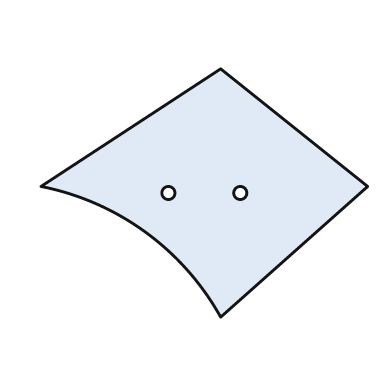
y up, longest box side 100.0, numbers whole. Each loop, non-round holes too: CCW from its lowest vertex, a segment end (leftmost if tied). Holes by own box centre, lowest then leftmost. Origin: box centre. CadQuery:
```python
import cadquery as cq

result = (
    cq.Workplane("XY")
    .moveTo(5.0, -38.0)
    .lineTo(50.0, 2.0)
    .lineTo(5.0, 38.0)
    .lineTo(-50.0, 2.0)
    .threePointArc((-18.0, -12.0), (5.0, -38.0))
    .close()
    .moveTo(-11.0, 0.0)
    .circle(2.0)
    .moveTo(11.0, 0.0)
    .circle(2.0)
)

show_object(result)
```